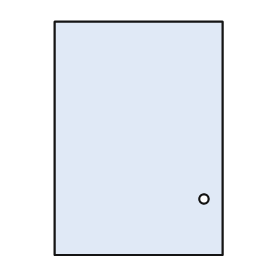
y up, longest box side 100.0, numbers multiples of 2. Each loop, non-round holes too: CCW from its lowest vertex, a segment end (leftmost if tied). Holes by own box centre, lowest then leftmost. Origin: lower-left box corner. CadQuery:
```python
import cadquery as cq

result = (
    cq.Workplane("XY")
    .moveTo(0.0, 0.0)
    .lineTo(72.0, 0.0)
    .lineTo(72.0, 100.0)
    .lineTo(0.0, 100.0)
    .close()
    .moveTo(64.0, 24.0)
    .circle(2.0)
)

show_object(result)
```